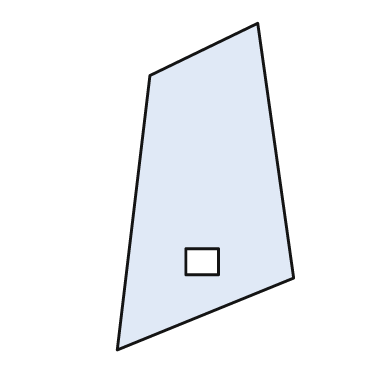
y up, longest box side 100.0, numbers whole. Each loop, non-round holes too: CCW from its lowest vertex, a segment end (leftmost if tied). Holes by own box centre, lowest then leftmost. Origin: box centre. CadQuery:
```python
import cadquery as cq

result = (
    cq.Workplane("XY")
    .moveTo(-27.0, -50.0)
    .lineTo(27.0, -28.0)
    .lineTo(16.0, 50.0)
    .lineTo(-17.0, 34.0)
    .close()
    .moveTo(-6.0, -27.0)
    .lineTo(4.0, -27.0)
    .lineTo(4.0, -19.0)
    .lineTo(-6.0, -19.0)
    .close()
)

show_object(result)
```